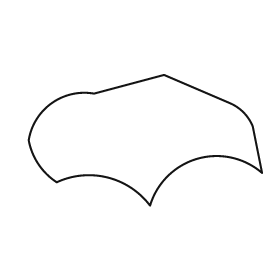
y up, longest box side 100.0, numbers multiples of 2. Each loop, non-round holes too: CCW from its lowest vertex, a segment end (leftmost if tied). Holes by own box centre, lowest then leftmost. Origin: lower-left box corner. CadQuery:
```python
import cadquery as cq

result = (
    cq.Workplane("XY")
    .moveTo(52.0, 0.0)
    .threePointArc((72.0, 20.0), (100.0, 14.0))
    .lineTo(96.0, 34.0)
    .threePointArc((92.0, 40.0), (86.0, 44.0))
    .lineTo(58.0, 56.0)
    .lineTo(28.0, 48.0)
    .threePointArc((10.0, 44.0), (0.0, 28.0))
    .threePointArc((4.0, 18.0), (12.0, 10.0))
    .threePointArc((34.0, 12.0), (52.0, 0.0))
    .close()
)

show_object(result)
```